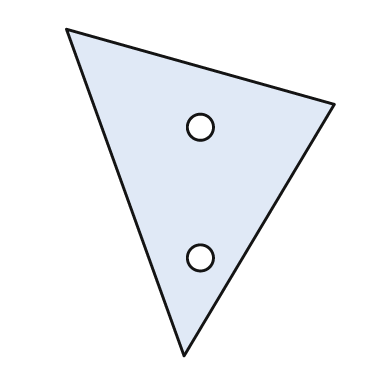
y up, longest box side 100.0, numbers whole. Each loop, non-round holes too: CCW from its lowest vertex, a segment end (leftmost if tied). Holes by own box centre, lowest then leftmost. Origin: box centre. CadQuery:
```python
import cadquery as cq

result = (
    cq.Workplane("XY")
    .moveTo(-5.0, -50.0)
    .lineTo(41.0, 27.0)
    .lineTo(-41.0, 50.0)
    .close()
    .moveTo(0.0, -20.0)
    .circle(4.0)
    .moveTo(0.0, 20.0)
    .circle(4.0)
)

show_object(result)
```